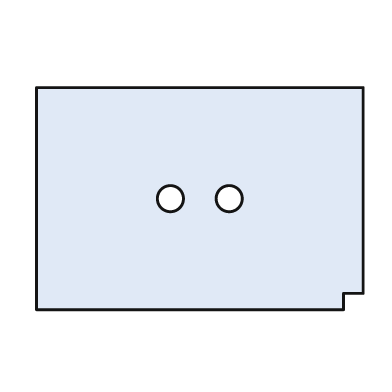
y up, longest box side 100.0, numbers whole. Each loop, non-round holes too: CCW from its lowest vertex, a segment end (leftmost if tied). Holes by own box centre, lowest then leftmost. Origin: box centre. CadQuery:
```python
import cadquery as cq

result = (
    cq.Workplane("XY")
    .moveTo(-50.0, -34.0)
    .lineTo(44.0, -34.0)
    .lineTo(44.0, -29.0)
    .lineTo(50.0, -29.0)
    .lineTo(50.0, 34.0)
    .lineTo(-50.0, 34.0)
    .close()
    .moveTo(-9.0, 0.0)
    .circle(4.0)
    .moveTo(9.0, 0.0)
    .circle(4.0)
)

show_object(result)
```